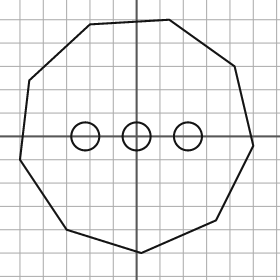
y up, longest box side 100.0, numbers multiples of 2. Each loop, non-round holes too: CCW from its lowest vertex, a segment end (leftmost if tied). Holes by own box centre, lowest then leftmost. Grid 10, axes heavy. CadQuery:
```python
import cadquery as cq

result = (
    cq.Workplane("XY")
    .moveTo(2.0, -50.0)
    .lineTo(34.0, -36.0)
    .lineTo(50.0, -4.0)
    .lineTo(42.0, 30.0)
    .lineTo(14.0, 50.0)
    .lineTo(-20.0, 48.0)
    .lineTo(-46.0, 24.0)
    .lineTo(-50.0, -10.0)
    .lineTo(-30.0, -40.0)
    .close()
    .moveTo(-22.0, 0.0)
    .circle(6.0)
    .moveTo(0.0, 0.0)
    .circle(6.0)
    .moveTo(22.0, 0.0)
    .circle(6.0)
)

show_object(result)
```